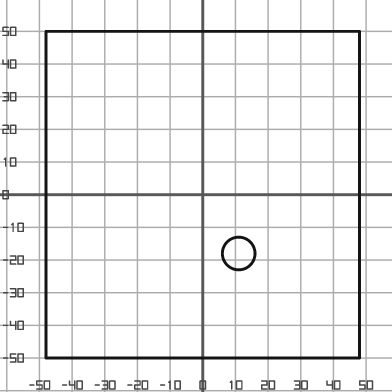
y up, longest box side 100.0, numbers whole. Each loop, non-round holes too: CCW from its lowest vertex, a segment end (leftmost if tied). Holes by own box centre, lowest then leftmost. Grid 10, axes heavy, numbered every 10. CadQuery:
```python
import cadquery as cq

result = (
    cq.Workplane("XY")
    .moveTo(-48.0, -50.0)
    .lineTo(48.0, -50.0)
    .lineTo(48.0, 50.0)
    .lineTo(-48.0, 50.0)
    .close()
    .moveTo(11.0, -18.0)
    .circle(5.0)
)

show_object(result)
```